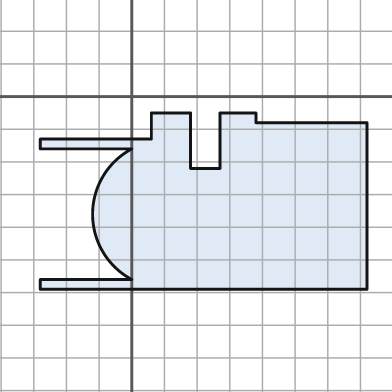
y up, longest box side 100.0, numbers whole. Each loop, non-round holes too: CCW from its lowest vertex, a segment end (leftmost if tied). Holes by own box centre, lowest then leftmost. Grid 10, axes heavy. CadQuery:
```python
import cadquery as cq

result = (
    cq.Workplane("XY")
    .moveTo(-28.0, -59.0)
    .lineTo(72.0, -59.0)
    .lineTo(72.0, -8.0)
    .lineTo(38.0, -8.0)
    .lineTo(38.0, -5.0)
    .lineTo(27.0, -5.0)
    .lineTo(27.0, -22.0)
    .lineTo(18.0, -22.0)
    .lineTo(18.0, -5.0)
    .lineTo(6.0, -5.0)
    .lineTo(6.0, -13.0)
    .lineTo(-28.0, -13.0)
    .lineTo(-28.0, -16.0)
    .lineTo(0.0, -16.0)
    .threePointArc((-12.0, -36.0), (0.0, -56.0))
    .lineTo(-28.0, -56.0)
    .close()
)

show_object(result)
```